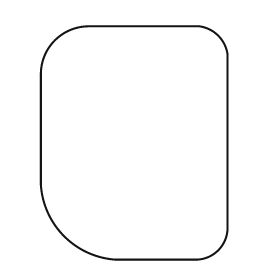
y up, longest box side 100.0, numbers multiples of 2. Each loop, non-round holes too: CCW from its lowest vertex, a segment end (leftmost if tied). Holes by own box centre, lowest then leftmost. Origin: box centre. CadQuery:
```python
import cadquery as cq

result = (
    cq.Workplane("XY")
    .moveTo(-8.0, -50.0)
    .lineTo(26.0, -50.0)
    .threePointArc((36.0, -46.0), (40.0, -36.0))
    .lineTo(40.0, 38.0)
    .threePointArc((36.0, 46.0), (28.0, 50.0))
    .lineTo(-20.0, 50.0)
    .threePointArc((-34.0, 44.0), (-40.0, 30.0))
    .lineTo(-40.0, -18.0)
    .threePointArc((-30.0, -40.0), (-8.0, -50.0))
    .close()
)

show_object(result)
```